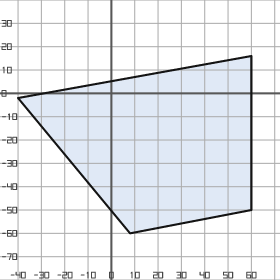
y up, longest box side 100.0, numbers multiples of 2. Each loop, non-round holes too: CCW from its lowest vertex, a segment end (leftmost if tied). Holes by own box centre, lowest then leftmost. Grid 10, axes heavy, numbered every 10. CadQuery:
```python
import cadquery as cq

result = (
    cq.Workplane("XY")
    .moveTo(8.0, -60.0)
    .lineTo(60.0, -50.0)
    .lineTo(60.0, 16.0)
    .lineTo(-40.0, -2.0)
    .close()
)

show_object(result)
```